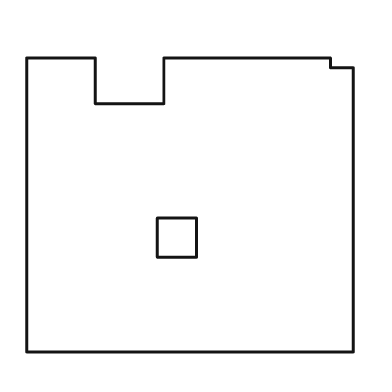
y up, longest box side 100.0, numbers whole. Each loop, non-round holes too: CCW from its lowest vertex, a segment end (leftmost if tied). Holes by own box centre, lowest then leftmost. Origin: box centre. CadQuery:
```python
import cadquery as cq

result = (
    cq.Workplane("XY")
    .moveTo(-50.0, -45.0)
    .lineTo(50.0, -45.0)
    .lineTo(50.0, 42.0)
    .lineTo(43.0, 42.0)
    .lineTo(43.0, 45.0)
    .lineTo(-8.0, 45.0)
    .lineTo(-8.0, 31.0)
    .lineTo(-29.0, 31.0)
    .lineTo(-29.0, 45.0)
    .lineTo(-50.0, 45.0)
    .close()
    .moveTo(-10.0, -16.0)
    .lineTo(2.0, -16.0)
    .lineTo(2.0, -4.0)
    .lineTo(-10.0, -4.0)
    .close()
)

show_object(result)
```